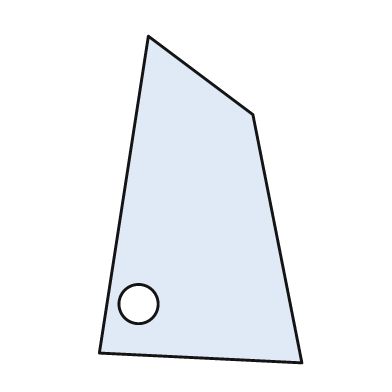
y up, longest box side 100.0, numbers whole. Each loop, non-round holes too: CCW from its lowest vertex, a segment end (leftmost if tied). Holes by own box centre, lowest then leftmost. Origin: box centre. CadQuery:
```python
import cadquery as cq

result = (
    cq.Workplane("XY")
    .moveTo(31.0, -50.0)
    .lineTo(16.0, 26.0)
    .lineTo(-16.0, 50.0)
    .lineTo(-31.0, -47.0)
    .close()
    .moveTo(-19.0, -32.0)
    .circle(6.0)
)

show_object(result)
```